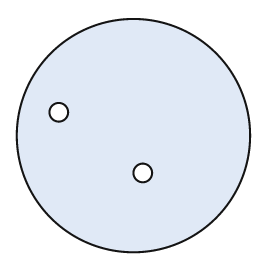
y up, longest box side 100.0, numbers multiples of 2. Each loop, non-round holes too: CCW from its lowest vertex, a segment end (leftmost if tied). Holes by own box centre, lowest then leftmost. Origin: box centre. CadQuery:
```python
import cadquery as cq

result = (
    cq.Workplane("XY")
    .moveTo(0.0, 0.0)
    .circle(50.0)
    .moveTo(4.0, -16.0)
    .circle(4.0)
    .moveTo(-32.0, 10.0)
    .circle(4.0)
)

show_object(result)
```